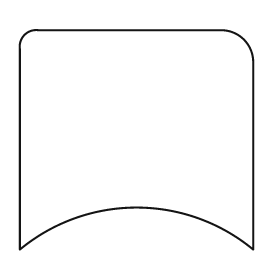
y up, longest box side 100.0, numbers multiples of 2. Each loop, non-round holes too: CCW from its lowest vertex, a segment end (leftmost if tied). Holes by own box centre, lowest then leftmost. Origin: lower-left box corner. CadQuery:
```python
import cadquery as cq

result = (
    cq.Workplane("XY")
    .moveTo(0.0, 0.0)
    .threePointArc((50.0, 18.0), (100.0, 0.0))
    .lineTo(100.0, 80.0)
    .threePointArc((96.0, 90.0), (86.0, 94.0))
    .lineTo(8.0, 94.0)
    .threePointArc((2.0, 92.0), (0.0, 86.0))
    .close()
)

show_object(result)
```